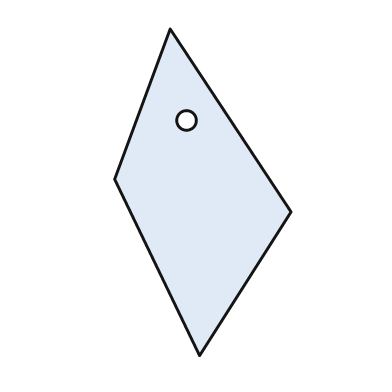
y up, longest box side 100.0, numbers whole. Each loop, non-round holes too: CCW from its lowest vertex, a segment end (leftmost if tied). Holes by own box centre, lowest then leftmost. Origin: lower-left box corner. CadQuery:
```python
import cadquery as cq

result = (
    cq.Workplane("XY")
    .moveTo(26.0, 0.0)
    .lineTo(54.0, 44.0)
    .lineTo(17.0, 100.0)
    .lineTo(0.0, 54.0)
    .close()
    .moveTo(22.0, 72.0)
    .circle(3.0)
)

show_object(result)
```